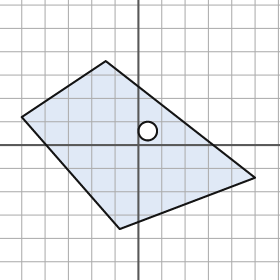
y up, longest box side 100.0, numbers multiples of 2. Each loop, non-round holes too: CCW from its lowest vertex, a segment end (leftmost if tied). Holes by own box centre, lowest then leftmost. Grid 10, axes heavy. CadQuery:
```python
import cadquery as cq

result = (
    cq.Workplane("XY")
    .moveTo(-8.0, -36.0)
    .lineTo(50.0, -14.0)
    .lineTo(-14.0, 36.0)
    .lineTo(-50.0, 12.0)
    .close()
    .moveTo(4.0, 6.0)
    .circle(4.0)
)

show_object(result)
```